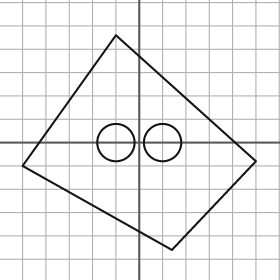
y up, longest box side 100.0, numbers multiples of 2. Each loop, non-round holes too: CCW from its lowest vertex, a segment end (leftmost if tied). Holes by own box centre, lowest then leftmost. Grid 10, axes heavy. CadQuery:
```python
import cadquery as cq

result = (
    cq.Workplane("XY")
    .moveTo(14.0, -46.0)
    .lineTo(50.0, -8.0)
    .lineTo(-10.0, 46.0)
    .lineTo(-50.0, -10.0)
    .close()
    .moveTo(-10.0, 0.0)
    .circle(8.0)
    .moveTo(10.0, 0.0)
    .circle(8.0)
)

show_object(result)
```